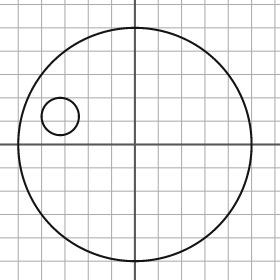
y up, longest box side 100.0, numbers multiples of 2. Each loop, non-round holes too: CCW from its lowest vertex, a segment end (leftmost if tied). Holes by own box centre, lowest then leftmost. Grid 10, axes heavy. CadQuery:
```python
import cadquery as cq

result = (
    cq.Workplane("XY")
    .moveTo(0.0, 0.0)
    .circle(50.0)
    .moveTo(-32.0, 12.0)
    .circle(8.0)
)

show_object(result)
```